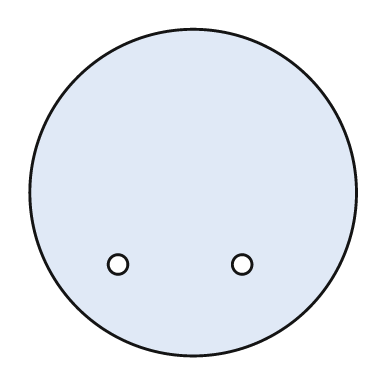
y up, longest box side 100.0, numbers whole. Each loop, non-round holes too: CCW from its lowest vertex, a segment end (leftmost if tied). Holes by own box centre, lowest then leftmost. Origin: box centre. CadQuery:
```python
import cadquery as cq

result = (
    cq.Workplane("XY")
    .moveTo(0.0, 0.0)
    .circle(50.0)
    .moveTo(-23.0, -22.0)
    .circle(3.0)
    .moveTo(15.0, -22.0)
    .circle(3.0)
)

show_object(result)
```